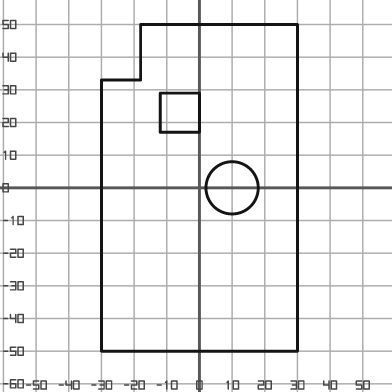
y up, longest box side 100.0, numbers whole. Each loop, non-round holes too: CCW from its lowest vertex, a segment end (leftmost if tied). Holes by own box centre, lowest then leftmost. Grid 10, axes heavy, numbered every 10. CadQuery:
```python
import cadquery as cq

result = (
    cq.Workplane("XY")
    .moveTo(-30.0, -50.0)
    .lineTo(30.0, -50.0)
    .lineTo(30.0, 50.0)
    .lineTo(-18.0, 50.0)
    .lineTo(-18.0, 33.0)
    .lineTo(-30.0, 33.0)
    .close()
    .moveTo(10.0, 0.0)
    .circle(8.0)
    .moveTo(-12.0, 17.0)
    .lineTo(0.0, 17.0)
    .lineTo(0.0, 29.0)
    .lineTo(-12.0, 29.0)
    .close()
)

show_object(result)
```